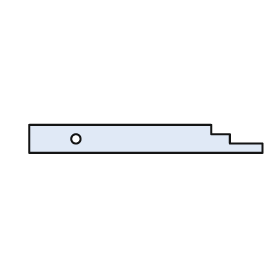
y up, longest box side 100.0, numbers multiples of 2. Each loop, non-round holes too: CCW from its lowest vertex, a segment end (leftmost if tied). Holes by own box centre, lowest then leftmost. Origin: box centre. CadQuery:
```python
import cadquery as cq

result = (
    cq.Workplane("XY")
    .moveTo(-50.0, -6.0)
    .lineTo(50.0, -6.0)
    .lineTo(50.0, -2.0)
    .lineTo(36.0, -2.0)
    .lineTo(36.0, 2.0)
    .lineTo(28.0, 2.0)
    .lineTo(28.0, 6.0)
    .lineTo(-50.0, 6.0)
    .close()
    .moveTo(-30.0, 0.0)
    .circle(2.0)
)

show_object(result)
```